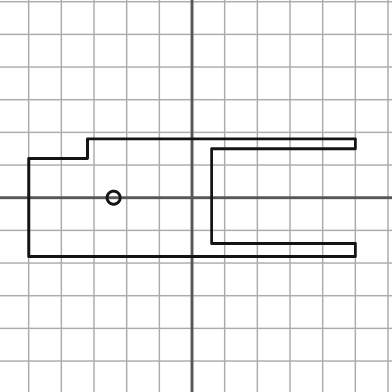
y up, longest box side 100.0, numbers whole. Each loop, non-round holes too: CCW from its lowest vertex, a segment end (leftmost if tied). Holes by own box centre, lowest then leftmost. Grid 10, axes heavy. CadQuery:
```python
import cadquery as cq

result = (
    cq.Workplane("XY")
    .moveTo(-50.0, -18.0)
    .lineTo(50.0, -18.0)
    .lineTo(50.0, -14.0)
    .lineTo(6.0, -14.0)
    .lineTo(6.0, 15.0)
    .lineTo(50.0, 15.0)
    .lineTo(50.0, 18.0)
    .lineTo(-32.0, 18.0)
    .lineTo(-32.0, 12.0)
    .lineTo(-50.0, 12.0)
    .close()
    .moveTo(-24.0, 0.0)
    .circle(2.0)
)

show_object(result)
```